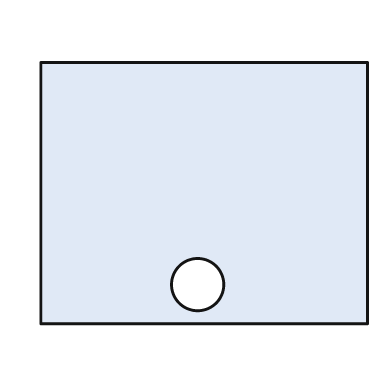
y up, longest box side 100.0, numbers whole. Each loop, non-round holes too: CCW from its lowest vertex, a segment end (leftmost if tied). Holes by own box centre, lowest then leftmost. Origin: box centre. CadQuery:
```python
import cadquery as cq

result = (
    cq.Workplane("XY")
    .moveTo(-50.0, -40.0)
    .lineTo(50.0, -40.0)
    .lineTo(50.0, 40.0)
    .lineTo(-50.0, 40.0)
    .close()
    .moveTo(-2.0, -28.0)
    .circle(8.0)
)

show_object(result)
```